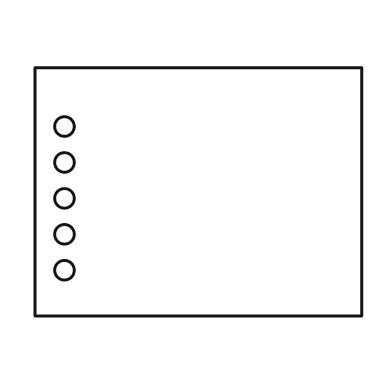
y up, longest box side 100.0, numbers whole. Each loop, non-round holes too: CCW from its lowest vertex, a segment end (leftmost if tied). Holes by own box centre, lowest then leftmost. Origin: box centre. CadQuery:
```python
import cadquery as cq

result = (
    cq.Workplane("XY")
    .moveTo(-50.0, -38.0)
    .lineTo(50.0, -38.0)
    .lineTo(50.0, 38.0)
    .lineTo(-50.0, 38.0)
    .close()
    .moveTo(-41.0, -24.0)
    .circle(3.0)
    .moveTo(-41.0, -13.0)
    .circle(3.0)
    .moveTo(-41.0, -2.0)
    .circle(3.0)
    .moveTo(-41.0, 9.0)
    .circle(3.0)
    .moveTo(-41.0, 20.0)
    .circle(3.0)
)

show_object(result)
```